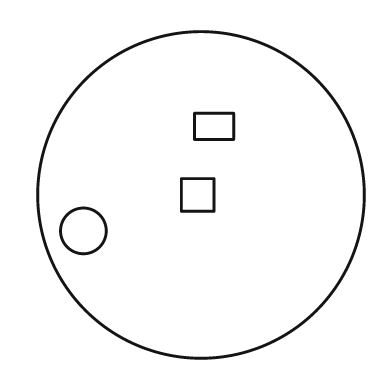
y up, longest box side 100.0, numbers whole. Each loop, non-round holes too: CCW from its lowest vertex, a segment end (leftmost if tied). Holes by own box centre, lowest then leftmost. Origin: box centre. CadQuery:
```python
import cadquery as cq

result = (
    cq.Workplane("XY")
    .moveTo(0.0, 0.0)
    .circle(50.0)
    .moveTo(-36.0, -11.0)
    .circle(7.0)
    .moveTo(-6.0, -5.0)
    .lineTo(4.0, -5.0)
    .lineTo(4.0, 5.0)
    .lineTo(-6.0, 5.0)
    .close()
    .moveTo(-2.0, 17.0)
    .lineTo(10.0, 17.0)
    .lineTo(10.0, 25.0)
    .lineTo(-2.0, 25.0)
    .close()
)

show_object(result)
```